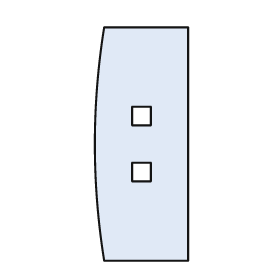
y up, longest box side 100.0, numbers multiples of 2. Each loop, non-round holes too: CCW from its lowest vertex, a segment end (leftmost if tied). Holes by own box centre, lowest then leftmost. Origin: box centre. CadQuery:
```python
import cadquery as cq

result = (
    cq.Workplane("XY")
    .moveTo(-16.0, -50.0)
    .lineTo(20.0, -50.0)
    .lineTo(20.0, 50.0)
    .lineTo(-16.0, 50.0)
    .threePointArc((-20.0, 0.0), (-16.0, -50.0))
    .close()
    .moveTo(-4.0, -16.0)
    .lineTo(4.0, -16.0)
    .lineTo(4.0, -8.0)
    .lineTo(-4.0, -8.0)
    .close()
    .moveTo(-4.0, 8.0)
    .lineTo(4.0, 8.0)
    .lineTo(4.0, 16.0)
    .lineTo(-4.0, 16.0)
    .close()
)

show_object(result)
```